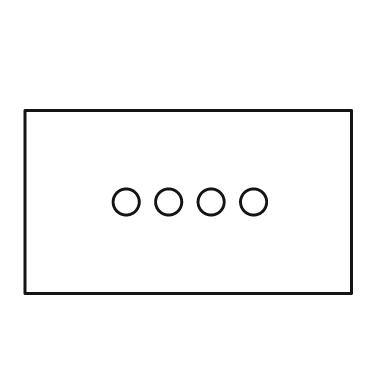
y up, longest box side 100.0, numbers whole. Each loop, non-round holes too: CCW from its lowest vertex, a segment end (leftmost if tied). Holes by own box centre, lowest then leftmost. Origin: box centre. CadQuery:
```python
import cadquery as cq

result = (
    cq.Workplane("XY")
    .moveTo(-50.0, -28.0)
    .lineTo(50.0, -28.0)
    .lineTo(50.0, 28.0)
    .lineTo(-50.0, 28.0)
    .close()
    .moveTo(-19.0, 0.0)
    .circle(4.0)
    .moveTo(-6.0, 0.0)
    .circle(4.0)
    .moveTo(7.0, 0.0)
    .circle(4.0)
    .moveTo(20.0, 0.0)
    .circle(4.0)
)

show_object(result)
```